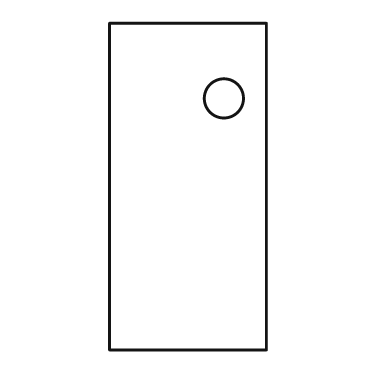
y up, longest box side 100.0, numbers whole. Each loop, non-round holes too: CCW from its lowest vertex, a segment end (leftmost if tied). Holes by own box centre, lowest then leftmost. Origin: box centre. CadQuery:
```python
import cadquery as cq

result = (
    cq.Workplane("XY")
    .moveTo(-24.0, -50.0)
    .lineTo(24.0, -50.0)
    .lineTo(24.0, 50.0)
    .lineTo(-24.0, 50.0)
    .close()
    .moveTo(11.0, 27.0)
    .circle(6.0)
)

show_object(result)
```